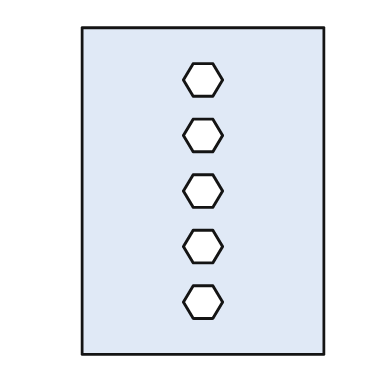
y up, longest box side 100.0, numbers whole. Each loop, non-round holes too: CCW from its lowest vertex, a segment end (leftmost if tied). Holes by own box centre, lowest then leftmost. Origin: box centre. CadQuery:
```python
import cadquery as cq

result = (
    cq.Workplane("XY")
    .moveTo(-37.0, -50.0)
    .lineTo(37.0, -50.0)
    .lineTo(37.0, 50.0)
    .lineTo(-37.0, 50.0)
    .close()
    .moveTo(-3.0, -39.0)
    .lineTo(3.0, -39.0)
    .lineTo(6.0, -34.0)
    .lineTo(3.0, -29.0)
    .lineTo(-3.0, -29.0)
    .lineTo(-6.0, -34.0)
    .close()
    .moveTo(-3.0, -22.0)
    .lineTo(3.0, -22.0)
    .lineTo(6.0, -17.0)
    .lineTo(3.0, -12.0)
    .lineTo(-3.0, -12.0)
    .lineTo(-6.0, -17.0)
    .close()
    .moveTo(-3.0, -5.0)
    .lineTo(3.0, -5.0)
    .lineTo(6.0, 0.0)
    .lineTo(3.0, 5.0)
    .lineTo(-3.0, 5.0)
    .lineTo(-6.0, 0.0)
    .close()
    .moveTo(-3.0, 12.0)
    .lineTo(3.0, 12.0)
    .lineTo(6.0, 17.0)
    .lineTo(3.0, 22.0)
    .lineTo(-3.0, 22.0)
    .lineTo(-6.0, 17.0)
    .close()
    .moveTo(-3.0, 29.0)
    .lineTo(3.0, 29.0)
    .lineTo(6.0, 34.0)
    .lineTo(3.0, 39.0)
    .lineTo(-3.0, 39.0)
    .lineTo(-6.0, 34.0)
    .close()
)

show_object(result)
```